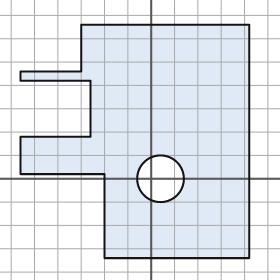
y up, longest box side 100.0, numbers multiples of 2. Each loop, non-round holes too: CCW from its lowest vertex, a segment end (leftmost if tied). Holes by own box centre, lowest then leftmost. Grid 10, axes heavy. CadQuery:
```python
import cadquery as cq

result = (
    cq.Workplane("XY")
    .moveTo(-20.0, -34.0)
    .lineTo(42.0, -34.0)
    .lineTo(42.0, 66.0)
    .lineTo(-30.0, 66.0)
    .lineTo(-30.0, 46.0)
    .lineTo(-56.0, 46.0)
    .lineTo(-56.0, 42.0)
    .lineTo(-26.0, 42.0)
    .lineTo(-26.0, 18.0)
    .lineTo(-56.0, 18.0)
    .lineTo(-56.0, 2.0)
    .lineTo(-20.0, 2.0)
    .close()
    .moveTo(4.0, 0.0)
    .circle(10.0)
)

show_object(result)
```